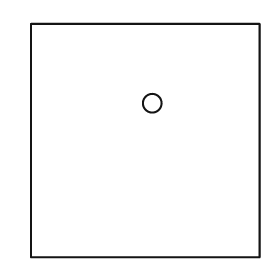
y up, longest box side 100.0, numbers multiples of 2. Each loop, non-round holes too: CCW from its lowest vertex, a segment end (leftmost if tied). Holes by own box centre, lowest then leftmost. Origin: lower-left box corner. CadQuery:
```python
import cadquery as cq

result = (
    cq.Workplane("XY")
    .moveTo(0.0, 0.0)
    .lineTo(98.0, 0.0)
    .lineTo(98.0, 100.0)
    .lineTo(0.0, 100.0)
    .close()
    .moveTo(52.0, 66.0)
    .circle(4.0)
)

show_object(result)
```